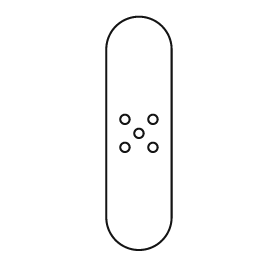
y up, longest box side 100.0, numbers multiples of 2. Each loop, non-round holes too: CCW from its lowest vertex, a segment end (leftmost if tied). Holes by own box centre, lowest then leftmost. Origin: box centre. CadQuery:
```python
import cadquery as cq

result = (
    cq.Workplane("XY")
    .moveTo(-14.0, -36.0)
    .threePointArc((0.0, -50.0), (14.0, -36.0))
    .lineTo(14.0, 36.0)
    .threePointArc((0.0, 50.0), (-14.0, 36.0))
    .close()
    .moveTo(-6.0, -6.0)
    .circle(2.0)
    .moveTo(6.0, -6.0)
    .circle(2.0)
    .moveTo(0.0, 0.0)
    .circle(2.0)
    .moveTo(-6.0, 6.0)
    .circle(2.0)
    .moveTo(6.0, 6.0)
    .circle(2.0)
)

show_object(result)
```